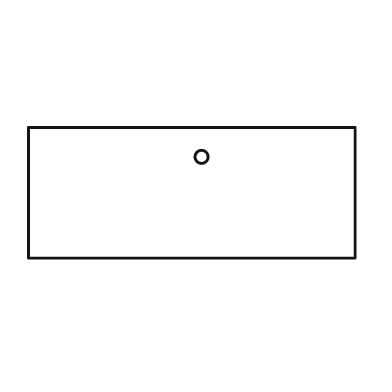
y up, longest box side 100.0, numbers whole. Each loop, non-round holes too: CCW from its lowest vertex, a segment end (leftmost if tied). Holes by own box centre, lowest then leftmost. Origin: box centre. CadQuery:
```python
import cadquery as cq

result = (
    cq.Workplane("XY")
    .moveTo(-50.0, -20.0)
    .lineTo(50.0, -20.0)
    .lineTo(50.0, 20.0)
    .lineTo(-50.0, 20.0)
    .close()
    .moveTo(3.0, 11.0)
    .circle(2.0)
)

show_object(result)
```